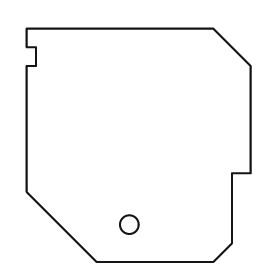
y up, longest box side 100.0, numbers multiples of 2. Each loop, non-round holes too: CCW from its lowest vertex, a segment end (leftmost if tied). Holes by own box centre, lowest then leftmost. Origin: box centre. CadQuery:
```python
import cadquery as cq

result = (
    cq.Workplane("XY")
    .moveTo(-18.0, -50.0)
    .lineTo(32.0, -50.0)
    .lineTo(40.0, -42.0)
    .lineTo(40.0, -12.0)
    .lineTo(48.0, -12.0)
    .lineTo(48.0, 34.0)
    .lineTo(32.0, 50.0)
    .lineTo(-48.0, 50.0)
    .lineTo(-48.0, 42.0)
    .lineTo(-44.0, 42.0)
    .lineTo(-44.0, 34.0)
    .lineTo(-48.0, 34.0)
    .lineTo(-48.0, -20.0)
    .close()
    .moveTo(-4.0, -34.0)
    .circle(4.0)
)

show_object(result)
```